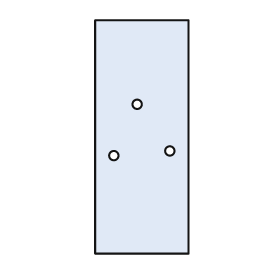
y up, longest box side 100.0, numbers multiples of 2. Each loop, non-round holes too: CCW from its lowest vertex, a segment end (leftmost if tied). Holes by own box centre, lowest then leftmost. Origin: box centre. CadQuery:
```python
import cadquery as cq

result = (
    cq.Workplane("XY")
    .moveTo(-20.0, -50.0)
    .lineTo(20.0, -50.0)
    .lineTo(20.0, 50.0)
    .lineTo(-20.0, 50.0)
    .close()
    .moveTo(-12.0, -8.0)
    .circle(2.0)
    .moveTo(12.0, -6.0)
    .circle(2.0)
    .moveTo(-2.0, 14.0)
    .circle(2.0)
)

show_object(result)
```